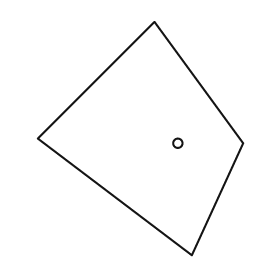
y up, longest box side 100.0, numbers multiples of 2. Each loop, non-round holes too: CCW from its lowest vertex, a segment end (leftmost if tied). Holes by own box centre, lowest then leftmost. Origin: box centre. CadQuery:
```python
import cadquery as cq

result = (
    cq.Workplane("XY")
    .moveTo(22.0, -50.0)
    .lineTo(44.0, -2.0)
    .lineTo(6.0, 50.0)
    .lineTo(-44.0, 0.0)
    .close()
    .moveTo(16.0, -2.0)
    .circle(2.0)
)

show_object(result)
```